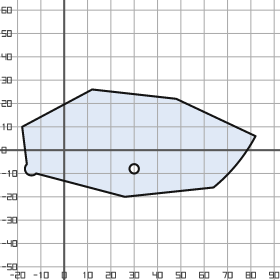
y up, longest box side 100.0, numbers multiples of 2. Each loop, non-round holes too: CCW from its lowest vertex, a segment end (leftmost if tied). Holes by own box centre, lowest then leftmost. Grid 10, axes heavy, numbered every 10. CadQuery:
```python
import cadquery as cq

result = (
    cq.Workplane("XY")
    .moveTo(26.0, -20.0)
    .lineTo(64.0, -16.0)
    .threePointArc((74.0, -6.0), (82.0, 6.0))
    .lineTo(48.0, 22.0)
    .lineTo(12.0, 26.0)
    .lineTo(-18.0, 10.0)
    .lineTo(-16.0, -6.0)
    .threePointArc((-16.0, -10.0), (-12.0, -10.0))
    .close()
    .moveTo(30.0, -8.0)
    .circle(2.0)
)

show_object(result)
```